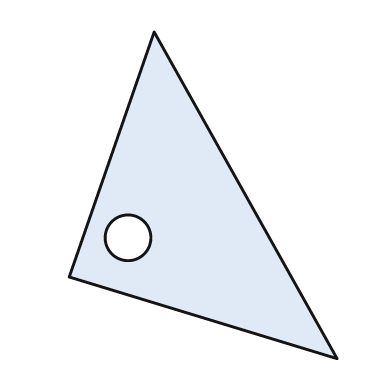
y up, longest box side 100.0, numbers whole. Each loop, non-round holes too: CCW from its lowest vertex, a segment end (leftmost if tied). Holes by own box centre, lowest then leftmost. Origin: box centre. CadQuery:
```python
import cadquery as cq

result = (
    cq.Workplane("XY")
    .moveTo(41.0, -50.0)
    .lineTo(-15.0, 50.0)
    .lineTo(-41.0, -25.0)
    .close()
    .moveTo(-23.0, -13.0)
    .circle(7.0)
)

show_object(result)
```